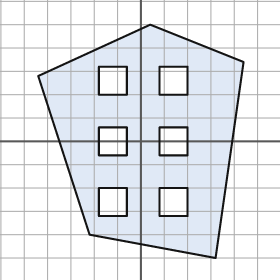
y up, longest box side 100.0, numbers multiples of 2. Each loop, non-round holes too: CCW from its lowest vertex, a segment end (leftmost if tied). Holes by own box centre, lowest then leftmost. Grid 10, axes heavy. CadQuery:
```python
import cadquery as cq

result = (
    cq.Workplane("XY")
    .moveTo(32.0, -50.0)
    .lineTo(44.0, 34.0)
    .lineTo(4.0, 50.0)
    .lineTo(-44.0, 28.0)
    .lineTo(-22.0, -40.0)
    .close()
    .moveTo(-18.0, -32.0)
    .lineTo(-6.0, -32.0)
    .lineTo(-6.0, -20.0)
    .lineTo(-18.0, -20.0)
    .close()
    .moveTo(8.0, -32.0)
    .lineTo(20.0, -32.0)
    .lineTo(20.0, -20.0)
    .lineTo(8.0, -20.0)
    .close()
    .moveTo(-18.0, -6.0)
    .lineTo(-6.0, -6.0)
    .lineTo(-6.0, 6.0)
    .lineTo(-18.0, 6.0)
    .close()
    .moveTo(8.0, -6.0)
    .lineTo(20.0, -6.0)
    .lineTo(20.0, 6.0)
    .lineTo(8.0, 6.0)
    .close()
    .moveTo(-18.0, 20.0)
    .lineTo(-6.0, 20.0)
    .lineTo(-6.0, 32.0)
    .lineTo(-18.0, 32.0)
    .close()
    .moveTo(8.0, 20.0)
    .lineTo(20.0, 20.0)
    .lineTo(20.0, 32.0)
    .lineTo(8.0, 32.0)
    .close()
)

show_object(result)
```